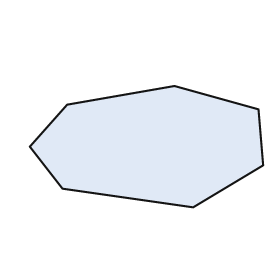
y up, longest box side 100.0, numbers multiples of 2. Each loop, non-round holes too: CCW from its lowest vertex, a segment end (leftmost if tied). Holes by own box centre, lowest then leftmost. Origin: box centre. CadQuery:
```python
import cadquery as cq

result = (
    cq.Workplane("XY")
    .moveTo(20.0, -26.0)
    .lineTo(50.0, -8.0)
    .lineTo(48.0, 16.0)
    .lineTo(12.0, 26.0)
    .lineTo(-34.0, 18.0)
    .lineTo(-50.0, 0.0)
    .lineTo(-36.0, -18.0)
    .close()
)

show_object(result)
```